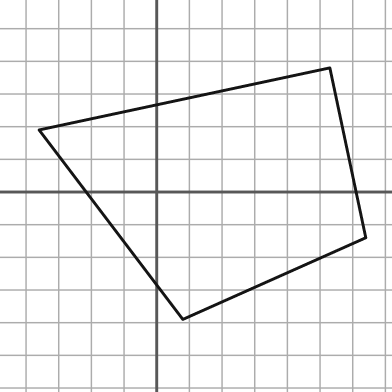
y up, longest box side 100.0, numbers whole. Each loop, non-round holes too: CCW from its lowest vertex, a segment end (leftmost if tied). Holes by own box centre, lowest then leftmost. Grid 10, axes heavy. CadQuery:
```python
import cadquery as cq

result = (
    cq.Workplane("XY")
    .moveTo(8.0, -39.0)
    .lineTo(64.0, -14.0)
    .lineTo(53.0, 38.0)
    .lineTo(-36.0, 19.0)
    .close()
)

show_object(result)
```